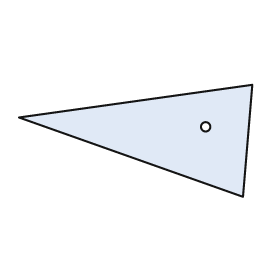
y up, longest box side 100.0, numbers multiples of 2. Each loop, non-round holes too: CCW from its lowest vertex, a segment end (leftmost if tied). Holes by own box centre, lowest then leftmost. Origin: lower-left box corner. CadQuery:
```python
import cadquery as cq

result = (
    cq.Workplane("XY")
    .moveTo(96.0, 0.0)
    .lineTo(100.0, 48.0)
    .lineTo(0.0, 34.0)
    .close()
    .moveTo(80.0, 30.0)
    .circle(2.0)
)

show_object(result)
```